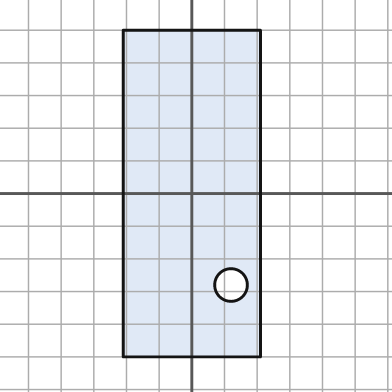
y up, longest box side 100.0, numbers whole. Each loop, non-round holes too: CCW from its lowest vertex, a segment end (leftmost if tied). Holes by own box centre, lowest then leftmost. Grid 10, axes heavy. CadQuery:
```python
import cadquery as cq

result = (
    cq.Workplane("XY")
    .moveTo(-21.0, -50.0)
    .lineTo(21.0, -50.0)
    .lineTo(21.0, 50.0)
    .lineTo(-21.0, 50.0)
    .close()
    .moveTo(12.0, -28.0)
    .circle(5.0)
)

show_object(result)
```